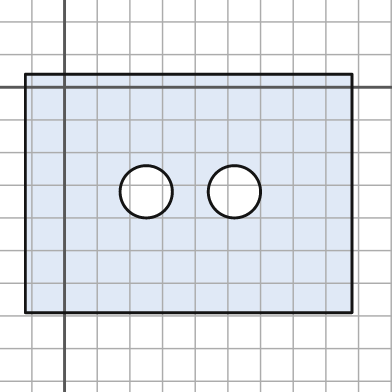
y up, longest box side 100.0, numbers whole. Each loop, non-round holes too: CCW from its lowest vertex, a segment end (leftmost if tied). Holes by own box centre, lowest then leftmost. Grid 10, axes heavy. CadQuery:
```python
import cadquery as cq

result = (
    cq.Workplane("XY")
    .moveTo(-12.0, -69.0)
    .lineTo(88.0, -69.0)
    .lineTo(88.0, 4.0)
    .lineTo(-12.0, 4.0)
    .close()
    .moveTo(25.0, -32.0)
    .circle(8.0)
    .moveTo(52.0, -32.0)
    .circle(8.0)
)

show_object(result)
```